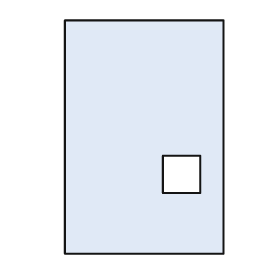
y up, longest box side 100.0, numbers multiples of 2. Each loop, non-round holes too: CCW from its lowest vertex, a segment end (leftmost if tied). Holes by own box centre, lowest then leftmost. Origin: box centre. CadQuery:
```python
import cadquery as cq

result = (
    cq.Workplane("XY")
    .moveTo(-34.0, -50.0)
    .lineTo(34.0, -50.0)
    .lineTo(34.0, 50.0)
    .lineTo(-34.0, 50.0)
    .close()
    .moveTo(8.0, -24.0)
    .lineTo(24.0, -24.0)
    .lineTo(24.0, -8.0)
    .lineTo(8.0, -8.0)
    .close()
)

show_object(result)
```